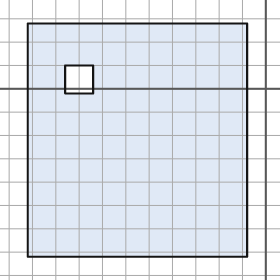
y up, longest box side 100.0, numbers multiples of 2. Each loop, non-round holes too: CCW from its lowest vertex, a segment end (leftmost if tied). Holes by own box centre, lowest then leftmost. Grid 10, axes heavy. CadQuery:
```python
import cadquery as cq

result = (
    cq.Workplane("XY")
    .moveTo(-102.0, -72.0)
    .lineTo(-8.0, -72.0)
    .lineTo(-8.0, 28.0)
    .lineTo(-102.0, 28.0)
    .close()
    .moveTo(-86.0, -2.0)
    .lineTo(-74.0, -2.0)
    .lineTo(-74.0, 10.0)
    .lineTo(-86.0, 10.0)
    .close()
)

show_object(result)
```